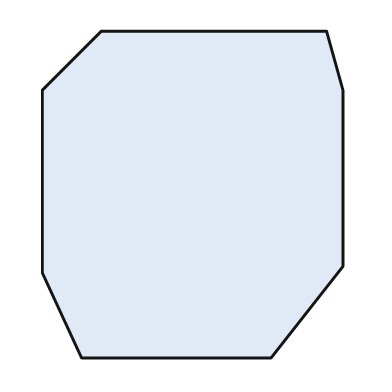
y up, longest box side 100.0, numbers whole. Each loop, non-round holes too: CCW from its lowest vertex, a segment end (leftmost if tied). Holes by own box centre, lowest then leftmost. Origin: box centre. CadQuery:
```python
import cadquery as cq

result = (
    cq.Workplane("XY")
    .moveTo(-34.0, -50.0)
    .lineTo(24.0, -50.0)
    .lineTo(46.0, -22.0)
    .lineTo(46.0, 32.0)
    .lineTo(41.0, 50.0)
    .lineTo(-28.0, 50.0)
    .lineTo(-46.0, 32.0)
    .lineTo(-46.0, -24.0)
    .close()
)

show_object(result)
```